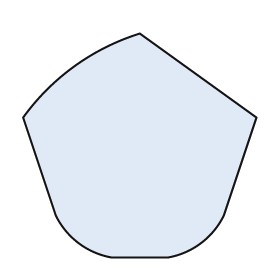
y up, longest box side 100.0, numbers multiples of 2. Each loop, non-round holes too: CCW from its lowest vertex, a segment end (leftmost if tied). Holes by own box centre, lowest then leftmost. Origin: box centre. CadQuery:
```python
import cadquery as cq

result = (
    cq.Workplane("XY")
    .moveTo(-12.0, -48.0)
    .lineTo(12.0, -48.0)
    .threePointArc((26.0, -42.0), (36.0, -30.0))
    .lineTo(50.0, 12.0)
    .lineTo(0.0, 48.0)
    .threePointArc((-28.0, 34.0), (-50.0, 12.0))
    .lineTo(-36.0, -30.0)
    .threePointArc((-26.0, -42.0), (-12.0, -48.0))
    .close()
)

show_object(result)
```